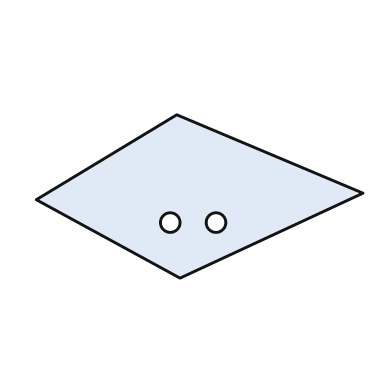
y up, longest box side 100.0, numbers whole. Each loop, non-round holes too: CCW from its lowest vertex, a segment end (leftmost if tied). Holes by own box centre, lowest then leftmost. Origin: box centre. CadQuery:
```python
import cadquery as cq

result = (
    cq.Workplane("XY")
    .moveTo(-6.0, -25.0)
    .lineTo(50.0, 1.0)
    .lineTo(-7.0, 25.0)
    .lineTo(-50.0, -1.0)
    .close()
    .moveTo(-9.0, -8.0)
    .circle(3.0)
    .moveTo(5.0, -8.0)
    .circle(3.0)
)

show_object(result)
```